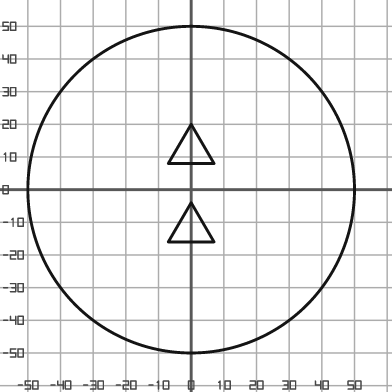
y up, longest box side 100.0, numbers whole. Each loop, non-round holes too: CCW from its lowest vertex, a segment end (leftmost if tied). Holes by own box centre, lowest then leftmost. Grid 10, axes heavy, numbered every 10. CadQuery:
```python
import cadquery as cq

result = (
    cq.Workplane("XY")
    .moveTo(0.0, 0.0)
    .circle(50.0)
    .moveTo(-7.0, -16.0)
    .lineTo(7.0, -16.0)
    .lineTo(0.0, -4.0)
    .close()
    .moveTo(-7.0, 8.0)
    .lineTo(7.0, 8.0)
    .lineTo(0.0, 20.0)
    .close()
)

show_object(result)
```